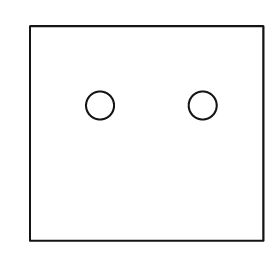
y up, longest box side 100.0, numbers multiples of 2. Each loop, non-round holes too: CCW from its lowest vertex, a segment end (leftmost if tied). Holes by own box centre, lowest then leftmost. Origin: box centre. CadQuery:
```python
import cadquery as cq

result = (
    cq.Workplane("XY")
    .moveTo(-50.0, -46.0)
    .lineTo(50.0, -46.0)
    .lineTo(50.0, 46.0)
    .lineTo(-50.0, 46.0)
    .close()
    .moveTo(-20.0, 12.0)
    .circle(6.0)
    .moveTo(24.0, 12.0)
    .circle(6.0)
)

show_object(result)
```